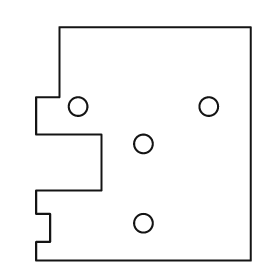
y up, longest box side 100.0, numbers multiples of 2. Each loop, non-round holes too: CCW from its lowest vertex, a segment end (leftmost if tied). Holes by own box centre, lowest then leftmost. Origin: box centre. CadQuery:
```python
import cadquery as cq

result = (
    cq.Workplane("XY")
    .moveTo(-46.0, -50.0)
    .lineTo(46.0, -50.0)
    .lineTo(46.0, 50.0)
    .lineTo(-36.0, 50.0)
    .lineTo(-36.0, 20.0)
    .lineTo(-46.0, 20.0)
    .lineTo(-46.0, 4.0)
    .lineTo(-18.0, 4.0)
    .lineTo(-18.0, -20.0)
    .lineTo(-46.0, -20.0)
    .lineTo(-46.0, -30.0)
    .lineTo(-40.0, -30.0)
    .lineTo(-40.0, -42.0)
    .lineTo(-46.0, -42.0)
    .close()
    .moveTo(0.0, -34.0)
    .circle(4.0)
    .moveTo(0.0, 0.0)
    .circle(4.0)
    .moveTo(-28.0, 16.0)
    .circle(4.0)
    .moveTo(28.0, 16.0)
    .circle(4.0)
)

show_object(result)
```